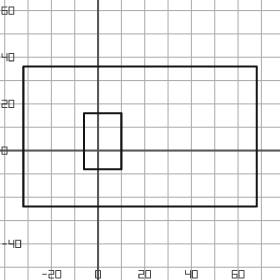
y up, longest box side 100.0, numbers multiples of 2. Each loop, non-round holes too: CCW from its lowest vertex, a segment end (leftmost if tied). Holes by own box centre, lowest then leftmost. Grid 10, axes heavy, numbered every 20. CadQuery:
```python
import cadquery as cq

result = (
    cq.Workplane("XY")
    .moveTo(-32.0, -24.0)
    .lineTo(68.0, -24.0)
    .lineTo(68.0, 36.0)
    .lineTo(-32.0, 36.0)
    .close()
    .moveTo(-6.0, -8.0)
    .lineTo(10.0, -8.0)
    .lineTo(10.0, 16.0)
    .lineTo(-6.0, 16.0)
    .close()
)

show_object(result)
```